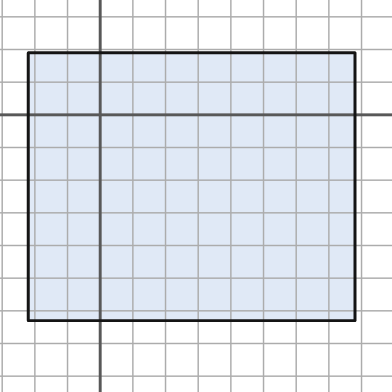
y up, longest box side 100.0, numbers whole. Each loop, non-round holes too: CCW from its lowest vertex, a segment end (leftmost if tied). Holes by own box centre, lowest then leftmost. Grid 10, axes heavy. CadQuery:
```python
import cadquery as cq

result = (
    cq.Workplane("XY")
    .moveTo(-22.0, -63.0)
    .lineTo(78.0, -63.0)
    .lineTo(78.0, 19.0)
    .lineTo(-22.0, 19.0)
    .close()
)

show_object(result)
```